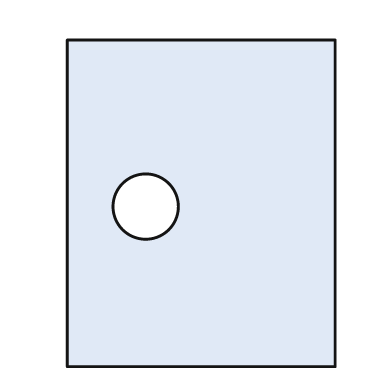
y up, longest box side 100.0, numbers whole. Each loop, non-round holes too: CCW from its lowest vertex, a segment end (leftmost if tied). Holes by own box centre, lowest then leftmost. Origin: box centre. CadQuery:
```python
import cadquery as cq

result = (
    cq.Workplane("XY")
    .moveTo(-41.0, -50.0)
    .lineTo(41.0, -50.0)
    .lineTo(41.0, 50.0)
    .lineTo(-41.0, 50.0)
    .close()
    .moveTo(-17.0, -1.0)
    .circle(10.0)
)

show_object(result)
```